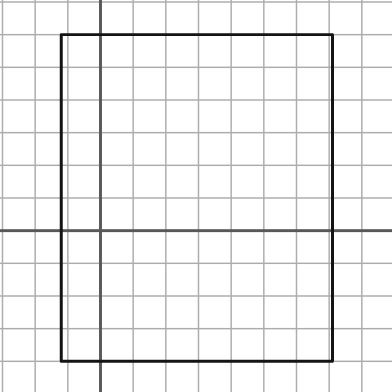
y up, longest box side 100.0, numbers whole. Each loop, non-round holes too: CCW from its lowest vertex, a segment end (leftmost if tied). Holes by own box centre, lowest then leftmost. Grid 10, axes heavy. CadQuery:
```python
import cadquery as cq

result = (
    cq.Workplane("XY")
    .moveTo(-12.0, -40.0)
    .lineTo(71.0, -40.0)
    .lineTo(71.0, 60.0)
    .lineTo(-12.0, 60.0)
    .close()
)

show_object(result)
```